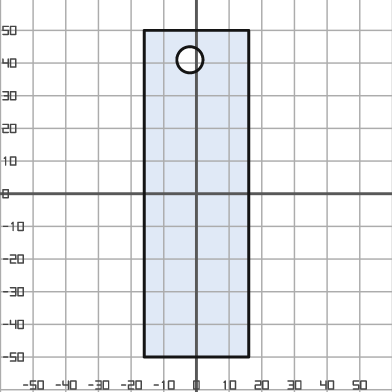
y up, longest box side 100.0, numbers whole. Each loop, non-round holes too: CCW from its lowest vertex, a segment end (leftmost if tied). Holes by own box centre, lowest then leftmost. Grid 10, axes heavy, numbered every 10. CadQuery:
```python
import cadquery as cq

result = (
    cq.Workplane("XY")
    .moveTo(-16.0, -50.0)
    .lineTo(16.0, -50.0)
    .lineTo(16.0, 50.0)
    .lineTo(-16.0, 50.0)
    .close()
    .moveTo(-2.0, 41.0)
    .circle(4.0)
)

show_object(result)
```